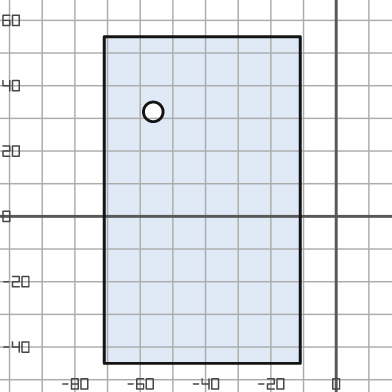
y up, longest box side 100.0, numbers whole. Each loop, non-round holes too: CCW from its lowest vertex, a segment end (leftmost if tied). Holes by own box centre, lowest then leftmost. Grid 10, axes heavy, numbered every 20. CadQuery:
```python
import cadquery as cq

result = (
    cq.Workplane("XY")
    .moveTo(-71.0, -45.0)
    .lineTo(-11.0, -45.0)
    .lineTo(-11.0, 55.0)
    .lineTo(-71.0, 55.0)
    .close()
    .moveTo(-56.0, 32.0)
    .circle(3.0)
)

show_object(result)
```